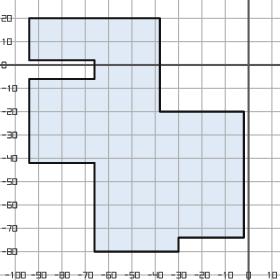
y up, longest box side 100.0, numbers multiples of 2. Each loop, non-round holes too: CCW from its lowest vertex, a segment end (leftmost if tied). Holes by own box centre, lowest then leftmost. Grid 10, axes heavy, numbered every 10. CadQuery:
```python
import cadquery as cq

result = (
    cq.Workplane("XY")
    .moveTo(-66.0, -80.0)
    .lineTo(-30.0, -80.0)
    .lineTo(-30.0, -74.0)
    .lineTo(-2.0, -74.0)
    .lineTo(-2.0, -20.0)
    .lineTo(-38.0, -20.0)
    .lineTo(-38.0, 20.0)
    .lineTo(-94.0, 20.0)
    .lineTo(-94.0, 2.0)
    .lineTo(-66.0, 2.0)
    .lineTo(-66.0, -6.0)
    .lineTo(-94.0, -6.0)
    .lineTo(-94.0, -42.0)
    .lineTo(-66.0, -42.0)
    .close()
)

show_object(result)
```